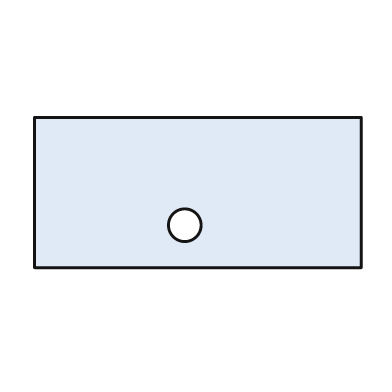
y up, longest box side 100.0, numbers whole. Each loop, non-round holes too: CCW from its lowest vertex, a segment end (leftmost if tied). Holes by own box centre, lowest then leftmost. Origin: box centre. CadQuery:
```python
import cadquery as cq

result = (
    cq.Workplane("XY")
    .moveTo(-50.0, -23.0)
    .lineTo(50.0, -23.0)
    .lineTo(50.0, 23.0)
    .lineTo(-50.0, 23.0)
    .close()
    .moveTo(-4.0, -10.0)
    .circle(5.0)
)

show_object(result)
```